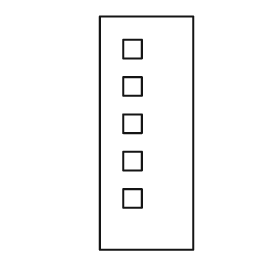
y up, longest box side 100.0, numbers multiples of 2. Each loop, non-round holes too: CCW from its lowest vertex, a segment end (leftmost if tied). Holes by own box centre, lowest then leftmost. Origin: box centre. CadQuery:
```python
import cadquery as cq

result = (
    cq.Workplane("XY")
    .moveTo(-20.0, -50.0)
    .lineTo(20.0, -50.0)
    .lineTo(20.0, 50.0)
    .lineTo(-20.0, 50.0)
    .close()
    .moveTo(-10.0, -32.0)
    .lineTo(-2.0, -32.0)
    .lineTo(-2.0, -24.0)
    .lineTo(-10.0, -24.0)
    .close()
    .moveTo(-10.0, -16.0)
    .lineTo(-2.0, -16.0)
    .lineTo(-2.0, -8.0)
    .lineTo(-10.0, -8.0)
    .close()
    .moveTo(-10.0, 0.0)
    .lineTo(-2.0, 0.0)
    .lineTo(-2.0, 8.0)
    .lineTo(-10.0, 8.0)
    .close()
    .moveTo(-10.0, 16.0)
    .lineTo(-2.0, 16.0)
    .lineTo(-2.0, 24.0)
    .lineTo(-10.0, 24.0)
    .close()
    .moveTo(-10.0, 32.0)
    .lineTo(-2.0, 32.0)
    .lineTo(-2.0, 40.0)
    .lineTo(-10.0, 40.0)
    .close()
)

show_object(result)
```